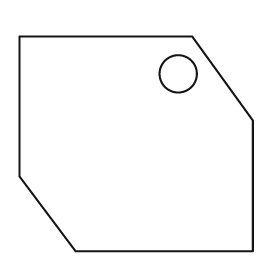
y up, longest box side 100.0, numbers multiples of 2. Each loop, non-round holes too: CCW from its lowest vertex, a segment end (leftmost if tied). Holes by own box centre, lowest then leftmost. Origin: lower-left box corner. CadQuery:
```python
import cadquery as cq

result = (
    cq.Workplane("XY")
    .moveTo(24.0, 0.0)
    .lineTo(100.0, 0.0)
    .lineTo(100.0, 56.0)
    .lineTo(74.0, 92.0)
    .lineTo(0.0, 92.0)
    .lineTo(0.0, 32.0)
    .close()
    .moveTo(68.0, 76.0)
    .circle(8.0)
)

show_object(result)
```